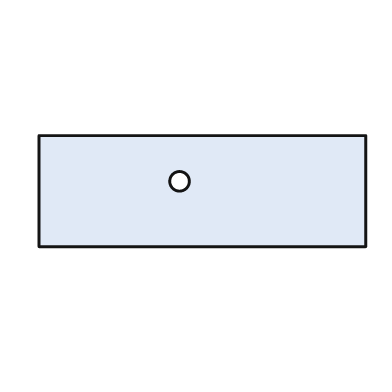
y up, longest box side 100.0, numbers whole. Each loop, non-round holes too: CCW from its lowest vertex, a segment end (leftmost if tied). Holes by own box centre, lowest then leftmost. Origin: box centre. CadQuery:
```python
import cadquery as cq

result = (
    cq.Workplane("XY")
    .moveTo(-50.0, -17.0)
    .lineTo(50.0, -17.0)
    .lineTo(50.0, 17.0)
    .lineTo(-50.0, 17.0)
    .close()
    .moveTo(-7.0, 3.0)
    .circle(3.0)
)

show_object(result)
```